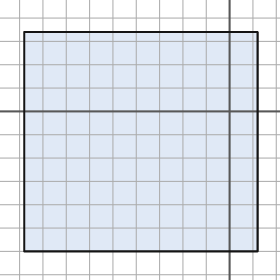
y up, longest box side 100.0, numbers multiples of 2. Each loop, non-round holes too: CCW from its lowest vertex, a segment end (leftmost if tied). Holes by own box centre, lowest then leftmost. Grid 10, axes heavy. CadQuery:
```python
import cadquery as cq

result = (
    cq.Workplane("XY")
    .moveTo(-88.0, -60.0)
    .lineTo(12.0, -60.0)
    .lineTo(12.0, 34.0)
    .lineTo(-88.0, 34.0)
    .close()
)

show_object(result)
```